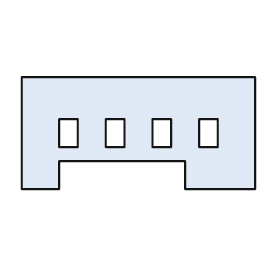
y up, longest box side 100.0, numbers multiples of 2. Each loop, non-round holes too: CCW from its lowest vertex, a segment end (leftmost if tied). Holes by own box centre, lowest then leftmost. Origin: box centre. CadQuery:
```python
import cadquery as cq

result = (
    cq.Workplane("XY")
    .moveTo(-50.0, -24.0)
    .lineTo(-34.0, -24.0)
    .lineTo(-34.0, -12.0)
    .lineTo(20.0, -12.0)
    .lineTo(20.0, -24.0)
    .lineTo(50.0, -24.0)
    .lineTo(50.0, 24.0)
    .lineTo(-50.0, 24.0)
    .close()
    .moveTo(-34.0, -6.0)
    .lineTo(-26.0, -6.0)
    .lineTo(-26.0, 6.0)
    .lineTo(-34.0, 6.0)
    .close()
    .moveTo(-14.0, -6.0)
    .lineTo(-6.0, -6.0)
    .lineTo(-6.0, 6.0)
    .lineTo(-14.0, 6.0)
    .close()
    .moveTo(6.0, -6.0)
    .lineTo(14.0, -6.0)
    .lineTo(14.0, 6.0)
    .lineTo(6.0, 6.0)
    .close()
    .moveTo(26.0, -6.0)
    .lineTo(34.0, -6.0)
    .lineTo(34.0, 6.0)
    .lineTo(26.0, 6.0)
    .close()
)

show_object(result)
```